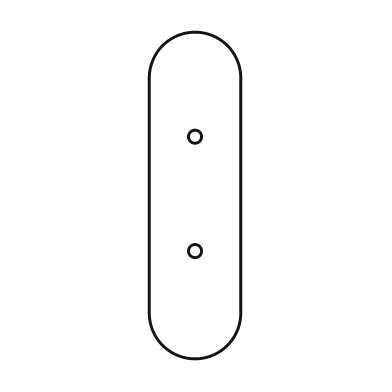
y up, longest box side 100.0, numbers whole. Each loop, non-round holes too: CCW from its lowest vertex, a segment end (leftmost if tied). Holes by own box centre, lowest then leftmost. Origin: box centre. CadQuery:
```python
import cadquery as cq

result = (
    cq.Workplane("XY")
    .moveTo(-14.0, -36.0)
    .threePointArc((0.0, -50.0), (14.0, -36.0))
    .lineTo(14.0, 36.0)
    .threePointArc((0.0, 50.0), (-14.0, 36.0))
    .close()
    .moveTo(0.0, -17.0)
    .circle(2.0)
    .moveTo(0.0, 18.0)
    .circle(2.0)
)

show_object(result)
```